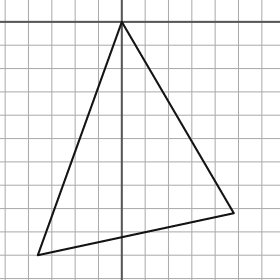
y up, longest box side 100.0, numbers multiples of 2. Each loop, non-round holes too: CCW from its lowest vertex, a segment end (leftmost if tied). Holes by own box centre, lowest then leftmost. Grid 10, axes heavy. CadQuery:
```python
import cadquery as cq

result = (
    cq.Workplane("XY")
    .moveTo(-36.0, -100.0)
    .lineTo(48.0, -82.0)
    .lineTo(0.0, 0.0)
    .close()
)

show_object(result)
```